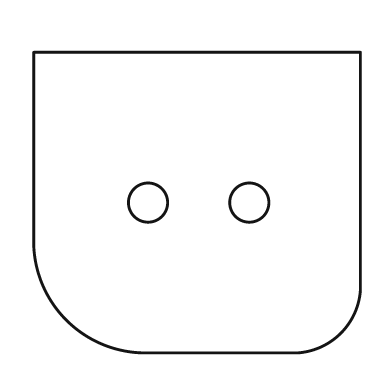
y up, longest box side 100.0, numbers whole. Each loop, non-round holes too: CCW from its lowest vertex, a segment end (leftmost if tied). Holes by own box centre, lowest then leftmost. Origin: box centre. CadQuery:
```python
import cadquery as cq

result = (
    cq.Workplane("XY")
    .moveTo(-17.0, -46.0)
    .lineTo(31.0, -46.0)
    .threePointArc((44.0, -40.0), (50.0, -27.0))
    .lineTo(50.0, 46.0)
    .lineTo(-50.0, 46.0)
    .lineTo(-50.0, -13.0)
    .threePointArc((-40.0, -36.0), (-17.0, -46.0))
    .close()
    .moveTo(-15.0, 0.0)
    .circle(6.0)
    .moveTo(16.0, 0.0)
    .circle(6.0)
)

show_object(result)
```